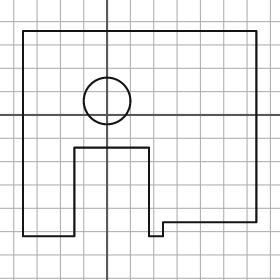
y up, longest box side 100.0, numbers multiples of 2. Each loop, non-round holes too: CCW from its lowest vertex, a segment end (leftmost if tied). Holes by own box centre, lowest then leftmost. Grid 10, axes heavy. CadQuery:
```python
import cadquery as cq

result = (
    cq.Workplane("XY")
    .moveTo(-36.0, -52.0)
    .lineTo(-14.0, -52.0)
    .lineTo(-14.0, -14.0)
    .lineTo(18.0, -14.0)
    .lineTo(18.0, -52.0)
    .lineTo(24.0, -52.0)
    .lineTo(24.0, -46.0)
    .lineTo(64.0, -46.0)
    .lineTo(64.0, 36.0)
    .lineTo(-36.0, 36.0)
    .close()
    .moveTo(0.0, 6.0)
    .circle(10.0)
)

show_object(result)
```